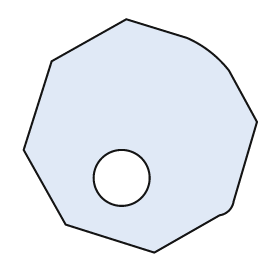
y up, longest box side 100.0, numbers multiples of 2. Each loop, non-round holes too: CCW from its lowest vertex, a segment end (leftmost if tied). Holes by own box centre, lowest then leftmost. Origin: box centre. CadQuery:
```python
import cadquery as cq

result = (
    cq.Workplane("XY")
    .moveTo(6.0, -50.0)
    .lineTo(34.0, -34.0)
    .threePointArc((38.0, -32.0), (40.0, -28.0))
    .lineTo(50.0, 6.0)
    .lineTo(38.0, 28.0)
    .threePointArc((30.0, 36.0), (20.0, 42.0))
    .lineTo(-6.0, 50.0)
    .lineTo(-38.0, 32.0)
    .lineTo(-50.0, -6.0)
    .lineTo(-32.0, -38.0)
    .close()
    .moveTo(-8.0, -18.0)
    .circle(12.0)
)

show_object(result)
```